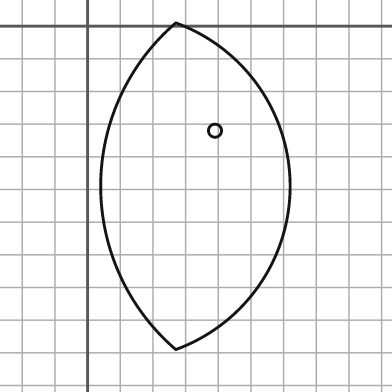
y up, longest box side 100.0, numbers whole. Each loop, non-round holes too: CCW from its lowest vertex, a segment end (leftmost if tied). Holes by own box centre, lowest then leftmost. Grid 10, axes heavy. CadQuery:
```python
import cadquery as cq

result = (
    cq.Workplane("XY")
    .moveTo(27.0, -99.0)
    .threePointArc((62.0, -49.0), (27.0, 1.0))
    .threePointArc((4.0, -49.0), (27.0, -99.0))
    .close()
    .moveTo(39.0, -32.0)
    .circle(2.0)
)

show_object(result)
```